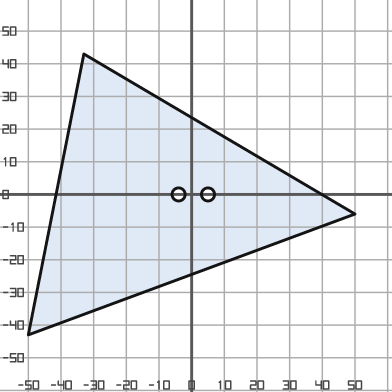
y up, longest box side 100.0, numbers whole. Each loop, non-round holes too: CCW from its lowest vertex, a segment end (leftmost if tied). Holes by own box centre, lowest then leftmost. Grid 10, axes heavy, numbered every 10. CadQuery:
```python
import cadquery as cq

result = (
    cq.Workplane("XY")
    .moveTo(-50.0, -43.0)
    .lineTo(50.0, -6.0)
    .lineTo(-33.0, 43.0)
    .close()
    .moveTo(-4.0, 0.0)
    .circle(2.0)
    .moveTo(5.0, 0.0)
    .circle(2.0)
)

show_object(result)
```